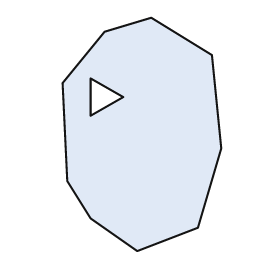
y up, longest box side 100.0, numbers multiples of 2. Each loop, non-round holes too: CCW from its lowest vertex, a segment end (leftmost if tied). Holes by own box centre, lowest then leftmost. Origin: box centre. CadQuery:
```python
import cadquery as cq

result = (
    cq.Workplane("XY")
    .moveTo(-2.0, -50.0)
    .lineTo(24.0, -40.0)
    .lineTo(34.0, -6.0)
    .lineTo(30.0, 34.0)
    .lineTo(4.0, 50.0)
    .lineTo(-16.0, 44.0)
    .lineTo(-34.0, 22.0)
    .lineTo(-32.0, -20.0)
    .lineTo(-22.0, -36.0)
    .close()
    .moveTo(-22.0, 8.0)
    .lineTo(-8.0, 16.0)
    .lineTo(-22.0, 24.0)
    .close()
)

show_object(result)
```